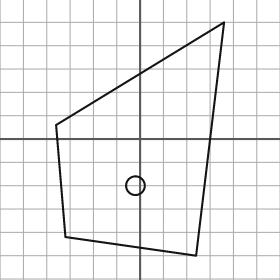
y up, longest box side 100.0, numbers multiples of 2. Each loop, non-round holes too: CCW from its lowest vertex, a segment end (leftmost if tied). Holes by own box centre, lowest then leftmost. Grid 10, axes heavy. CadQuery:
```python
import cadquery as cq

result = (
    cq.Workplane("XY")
    .moveTo(24.0, -50.0)
    .lineTo(36.0, 50.0)
    .lineTo(-36.0, 6.0)
    .lineTo(-32.0, -42.0)
    .close()
    .moveTo(-2.0, -20.0)
    .circle(4.0)
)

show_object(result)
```